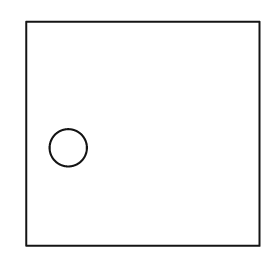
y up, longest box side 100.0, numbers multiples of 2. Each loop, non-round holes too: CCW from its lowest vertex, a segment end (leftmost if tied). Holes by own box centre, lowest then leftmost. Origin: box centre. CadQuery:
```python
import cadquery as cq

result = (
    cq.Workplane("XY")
    .moveTo(-50.0, -48.0)
    .lineTo(50.0, -48.0)
    .lineTo(50.0, 48.0)
    .lineTo(-50.0, 48.0)
    .close()
    .moveTo(-32.0, -6.0)
    .circle(8.0)
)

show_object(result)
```